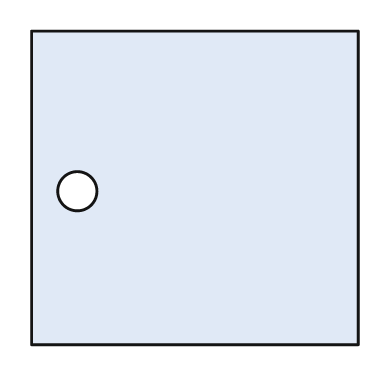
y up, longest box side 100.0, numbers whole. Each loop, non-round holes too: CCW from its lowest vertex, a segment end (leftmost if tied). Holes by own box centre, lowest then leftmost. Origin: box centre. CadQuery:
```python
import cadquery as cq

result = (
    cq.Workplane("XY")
    .moveTo(-50.0, -48.0)
    .lineTo(50.0, -48.0)
    .lineTo(50.0, 48.0)
    .lineTo(-50.0, 48.0)
    .close()
    .moveTo(-36.0, -1.0)
    .circle(6.0)
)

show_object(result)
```